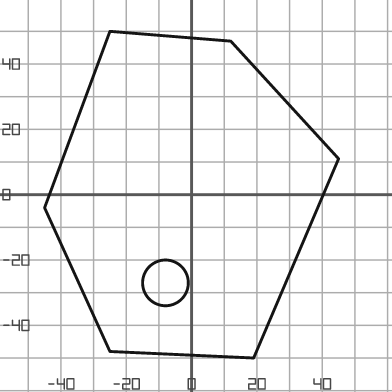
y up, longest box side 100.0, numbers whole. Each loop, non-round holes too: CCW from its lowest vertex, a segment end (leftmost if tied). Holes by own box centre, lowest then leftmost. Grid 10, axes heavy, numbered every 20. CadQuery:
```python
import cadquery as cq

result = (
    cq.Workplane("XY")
    .moveTo(19.0, -50.0)
    .lineTo(45.0, 11.0)
    .lineTo(12.0, 47.0)
    .lineTo(-25.0, 50.0)
    .lineTo(-45.0, -4.0)
    .lineTo(-25.0, -48.0)
    .close()
    .moveTo(-8.0, -27.0)
    .circle(7.0)
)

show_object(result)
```